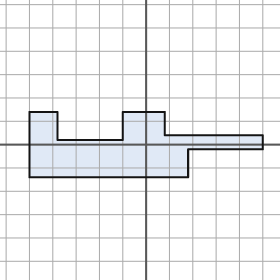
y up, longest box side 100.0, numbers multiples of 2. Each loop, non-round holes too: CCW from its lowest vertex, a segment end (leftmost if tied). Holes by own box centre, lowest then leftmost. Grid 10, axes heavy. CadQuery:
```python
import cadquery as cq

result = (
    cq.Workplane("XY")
    .moveTo(-50.0, -14.0)
    .lineTo(18.0, -14.0)
    .lineTo(18.0, -2.0)
    .lineTo(50.0, -2.0)
    .lineTo(50.0, 4.0)
    .lineTo(8.0, 4.0)
    .lineTo(8.0, 14.0)
    .lineTo(-10.0, 14.0)
    .lineTo(-10.0, 2.0)
    .lineTo(-38.0, 2.0)
    .lineTo(-38.0, 14.0)
    .lineTo(-50.0, 14.0)
    .close()
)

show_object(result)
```